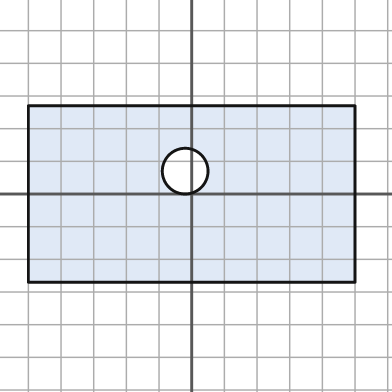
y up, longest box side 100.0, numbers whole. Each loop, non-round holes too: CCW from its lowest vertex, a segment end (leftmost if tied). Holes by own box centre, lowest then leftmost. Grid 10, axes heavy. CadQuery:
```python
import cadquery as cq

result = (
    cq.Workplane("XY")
    .moveTo(-50.0, -27.0)
    .lineTo(50.0, -27.0)
    .lineTo(50.0, 27.0)
    .lineTo(-50.0, 27.0)
    .close()
    .moveTo(-2.0, 7.0)
    .circle(7.0)
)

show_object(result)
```